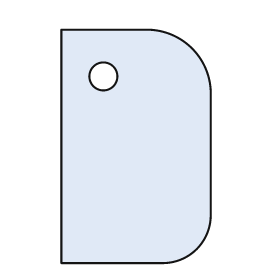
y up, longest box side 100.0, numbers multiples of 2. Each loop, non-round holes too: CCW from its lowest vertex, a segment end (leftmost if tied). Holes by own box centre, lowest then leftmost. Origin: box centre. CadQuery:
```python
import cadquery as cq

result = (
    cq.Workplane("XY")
    .moveTo(-32.0, -50.0)
    .lineTo(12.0, -50.0)
    .threePointArc((26.0, -44.0), (32.0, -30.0))
    .lineTo(32.0, 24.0)
    .threePointArc((24.0, 42.0), (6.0, 50.0))
    .lineTo(-32.0, 50.0)
    .close()
    .moveTo(-14.0, 30.0)
    .circle(6.0)
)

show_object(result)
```